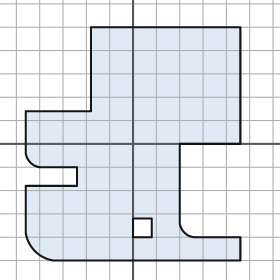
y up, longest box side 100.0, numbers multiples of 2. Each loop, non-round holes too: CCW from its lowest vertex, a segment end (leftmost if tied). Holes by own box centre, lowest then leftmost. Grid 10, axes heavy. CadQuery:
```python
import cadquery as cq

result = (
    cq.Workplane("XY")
    .moveTo(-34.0, -50.0)
    .lineTo(46.0, -50.0)
    .lineTo(46.0, -40.0)
    .lineTo(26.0, -40.0)
    .threePointArc((22.0, -38.0), (20.0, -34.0))
    .lineTo(20.0, 0.0)
    .lineTo(46.0, 0.0)
    .lineTo(46.0, 50.0)
    .lineTo(-18.0, 50.0)
    .lineTo(-18.0, 14.0)
    .lineTo(-46.0, 14.0)
    .lineTo(-46.0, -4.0)
    .threePointArc((-44.0, -8.0), (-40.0, -10.0))
    .lineTo(-24.0, -10.0)
    .lineTo(-24.0, -18.0)
    .lineTo(-46.0, -18.0)
    .lineTo(-46.0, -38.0)
    .threePointArc((-42.0, -46.0), (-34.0, -50.0))
    .close()
    .moveTo(0.0, -40.0)
    .lineTo(8.0, -40.0)
    .lineTo(8.0, -32.0)
    .lineTo(0.0, -32.0)
    .close()
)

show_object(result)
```